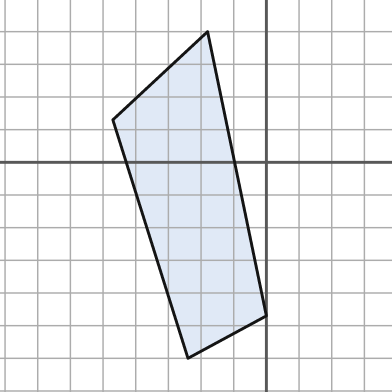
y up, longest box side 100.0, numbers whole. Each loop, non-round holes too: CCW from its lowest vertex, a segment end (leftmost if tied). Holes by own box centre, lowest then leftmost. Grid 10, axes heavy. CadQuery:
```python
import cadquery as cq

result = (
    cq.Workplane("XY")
    .moveTo(-24.0, -60.0)
    .lineTo(0.0, -47.0)
    .lineTo(-18.0, 40.0)
    .lineTo(-47.0, 13.0)
    .close()
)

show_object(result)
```